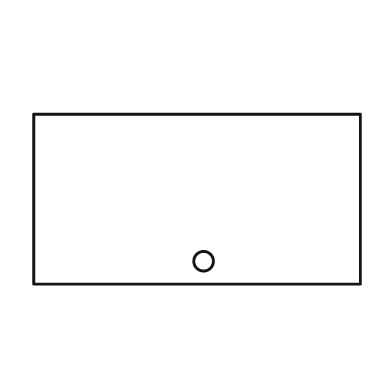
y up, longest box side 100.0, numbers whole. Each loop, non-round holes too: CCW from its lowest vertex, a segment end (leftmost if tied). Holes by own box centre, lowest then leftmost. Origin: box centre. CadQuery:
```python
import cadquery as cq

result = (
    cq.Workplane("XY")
    .moveTo(-50.0, -26.0)
    .lineTo(50.0, -26.0)
    .lineTo(50.0, 26.0)
    .lineTo(-50.0, 26.0)
    .close()
    .moveTo(2.0, -19.0)
    .circle(3.0)
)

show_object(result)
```